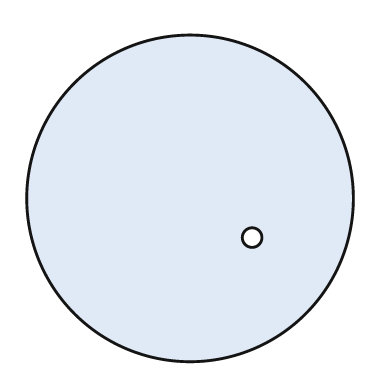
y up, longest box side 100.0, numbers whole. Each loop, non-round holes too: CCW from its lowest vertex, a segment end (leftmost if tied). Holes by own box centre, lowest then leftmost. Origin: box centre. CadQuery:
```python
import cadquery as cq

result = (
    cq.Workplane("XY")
    .moveTo(0.0, 0.0)
    .circle(50.0)
    .moveTo(19.0, -12.0)
    .circle(3.0)
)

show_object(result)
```